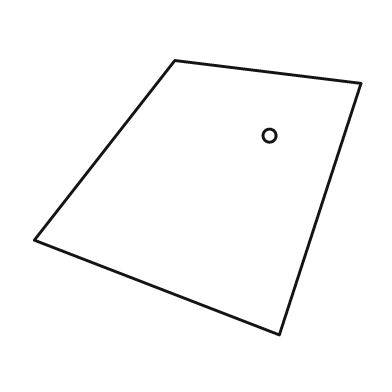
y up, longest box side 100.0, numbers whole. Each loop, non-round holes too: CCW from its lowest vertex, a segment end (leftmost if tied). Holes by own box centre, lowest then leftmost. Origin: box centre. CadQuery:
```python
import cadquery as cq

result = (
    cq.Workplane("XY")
    .moveTo(25.0, -42.0)
    .lineTo(50.0, 35.0)
    .lineTo(-7.0, 42.0)
    .lineTo(-50.0, -13.0)
    .close()
    .moveTo(22.0, 19.0)
    .circle(2.0)
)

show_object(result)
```